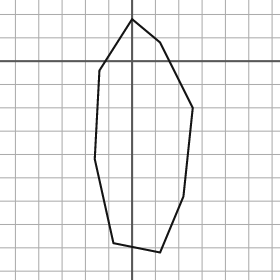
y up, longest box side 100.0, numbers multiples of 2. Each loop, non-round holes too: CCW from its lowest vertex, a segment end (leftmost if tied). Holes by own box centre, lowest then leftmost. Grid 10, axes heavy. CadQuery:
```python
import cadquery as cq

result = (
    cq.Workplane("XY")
    .moveTo(12.0, -82.0)
    .lineTo(22.0, -58.0)
    .lineTo(26.0, -20.0)
    .lineTo(12.0, 8.0)
    .lineTo(0.0, 18.0)
    .lineTo(-14.0, -4.0)
    .lineTo(-16.0, -42.0)
    .lineTo(-8.0, -78.0)
    .close()
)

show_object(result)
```